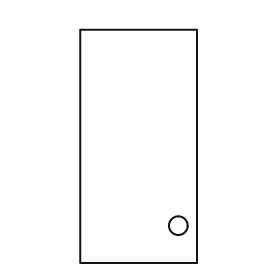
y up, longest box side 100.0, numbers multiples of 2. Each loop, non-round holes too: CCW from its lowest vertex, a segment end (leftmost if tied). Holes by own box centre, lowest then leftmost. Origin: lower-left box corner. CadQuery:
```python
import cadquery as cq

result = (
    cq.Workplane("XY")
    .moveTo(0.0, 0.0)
    .lineTo(50.0, 0.0)
    .lineTo(50.0, 100.0)
    .lineTo(0.0, 100.0)
    .close()
    .moveTo(42.0, 16.0)
    .circle(4.0)
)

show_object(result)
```